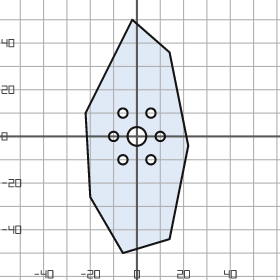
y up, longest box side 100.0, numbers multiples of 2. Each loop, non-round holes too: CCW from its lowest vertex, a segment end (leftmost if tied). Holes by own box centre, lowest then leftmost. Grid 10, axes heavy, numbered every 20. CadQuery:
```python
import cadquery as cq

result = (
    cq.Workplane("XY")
    .moveTo(-6.0, -50.0)
    .lineTo(14.0, -44.0)
    .lineTo(22.0, -4.0)
    .lineTo(14.0, 36.0)
    .lineTo(-2.0, 50.0)
    .lineTo(-22.0, 10.0)
    .lineTo(-20.0, -26.0)
    .close()
    .moveTo(-6.0, -10.0)
    .circle(2.0)
    .moveTo(6.0, -10.0)
    .circle(2.0)
    .moveTo(-10.0, 0.0)
    .circle(2.0)
    .moveTo(0.0, 0.0)
    .circle(4.0)
    .moveTo(10.0, 0.0)
    .circle(2.0)
    .moveTo(-6.0, 10.0)
    .circle(2.0)
    .moveTo(6.0, 10.0)
    .circle(2.0)
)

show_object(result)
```